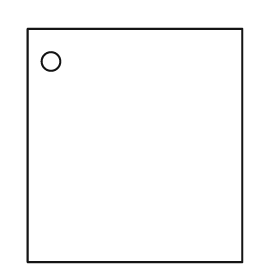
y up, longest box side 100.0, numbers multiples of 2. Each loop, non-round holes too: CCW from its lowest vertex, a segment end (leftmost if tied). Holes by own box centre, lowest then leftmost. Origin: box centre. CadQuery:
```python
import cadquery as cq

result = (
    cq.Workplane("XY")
    .moveTo(-46.0, -50.0)
    .lineTo(46.0, -50.0)
    .lineTo(46.0, 50.0)
    .lineTo(-46.0, 50.0)
    .close()
    .moveTo(-36.0, 36.0)
    .circle(4.0)
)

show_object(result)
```